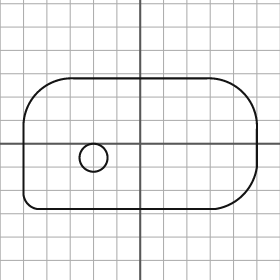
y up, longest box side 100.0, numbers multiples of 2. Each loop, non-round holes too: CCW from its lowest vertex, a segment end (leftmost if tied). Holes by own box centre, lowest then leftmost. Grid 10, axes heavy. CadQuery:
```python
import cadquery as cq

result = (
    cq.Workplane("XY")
    .moveTo(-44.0, -28.0)
    .lineTo(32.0, -28.0)
    .threePointArc((44.0, -22.0), (50.0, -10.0))
    .lineTo(50.0, 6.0)
    .threePointArc((44.0, 22.0), (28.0, 28.0))
    .lineTo(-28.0, 28.0)
    .threePointArc((-44.0, 22.0), (-50.0, 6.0))
    .lineTo(-50.0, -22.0)
    .threePointArc((-48.0, -26.0), (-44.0, -28.0))
    .close()
    .moveTo(-20.0, -6.0)
    .circle(6.0)
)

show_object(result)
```